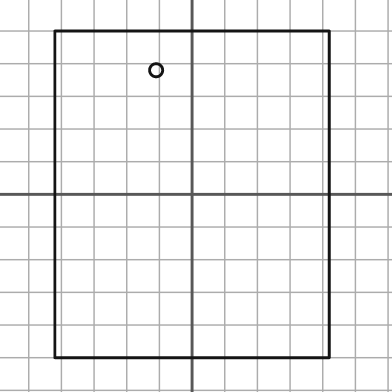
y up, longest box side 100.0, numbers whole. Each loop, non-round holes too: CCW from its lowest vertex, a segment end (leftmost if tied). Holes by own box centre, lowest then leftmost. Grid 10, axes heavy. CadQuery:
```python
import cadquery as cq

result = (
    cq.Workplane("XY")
    .moveTo(-42.0, -50.0)
    .lineTo(42.0, -50.0)
    .lineTo(42.0, 50.0)
    .lineTo(-42.0, 50.0)
    .close()
    .moveTo(-11.0, 38.0)
    .circle(2.0)
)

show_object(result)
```